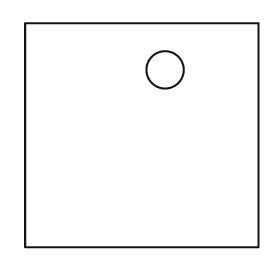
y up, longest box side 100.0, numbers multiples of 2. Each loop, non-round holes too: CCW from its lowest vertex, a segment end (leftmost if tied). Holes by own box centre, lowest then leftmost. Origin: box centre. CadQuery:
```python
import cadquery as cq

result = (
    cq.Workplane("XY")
    .moveTo(-50.0, -48.0)
    .lineTo(50.0, -48.0)
    .lineTo(50.0, 48.0)
    .lineTo(-50.0, 48.0)
    .close()
    .moveTo(10.0, 28.0)
    .circle(8.0)
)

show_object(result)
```